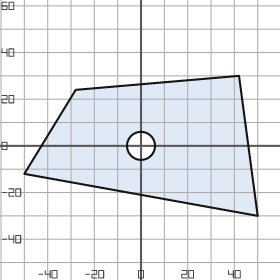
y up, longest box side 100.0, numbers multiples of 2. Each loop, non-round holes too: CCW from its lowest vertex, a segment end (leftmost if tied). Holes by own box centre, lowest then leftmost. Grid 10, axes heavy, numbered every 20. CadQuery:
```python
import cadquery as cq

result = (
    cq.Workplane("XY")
    .moveTo(50.0, -30.0)
    .lineTo(42.0, 30.0)
    .lineTo(-28.0, 24.0)
    .lineTo(-50.0, -12.0)
    .close()
    .moveTo(0.0, 0.0)
    .circle(6.0)
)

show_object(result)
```